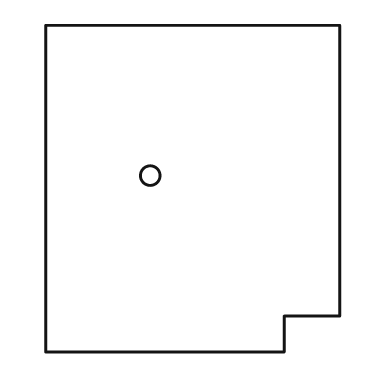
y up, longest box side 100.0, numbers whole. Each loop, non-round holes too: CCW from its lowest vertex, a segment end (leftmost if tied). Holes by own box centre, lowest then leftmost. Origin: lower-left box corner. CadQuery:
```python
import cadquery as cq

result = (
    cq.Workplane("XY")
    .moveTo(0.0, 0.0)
    .lineTo(73.0, 0.0)
    .lineTo(73.0, 11.0)
    .lineTo(90.0, 11.0)
    .lineTo(90.0, 100.0)
    .lineTo(0.0, 100.0)
    .close()
    .moveTo(32.0, 54.0)
    .circle(3.0)
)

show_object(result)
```